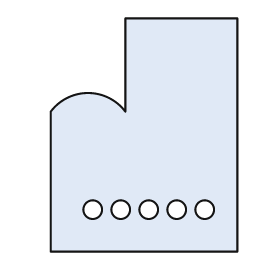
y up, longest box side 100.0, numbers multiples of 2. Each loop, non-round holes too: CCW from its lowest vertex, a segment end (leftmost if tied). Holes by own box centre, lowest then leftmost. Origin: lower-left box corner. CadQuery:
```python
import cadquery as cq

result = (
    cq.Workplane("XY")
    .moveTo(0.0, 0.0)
    .lineTo(80.0, 0.0)
    .lineTo(80.0, 100.0)
    .lineTo(32.0, 100.0)
    .lineTo(32.0, 60.0)
    .threePointArc((16.0, 68.0), (0.0, 60.0))
    .close()
    .moveTo(18.0, 18.0)
    .circle(4.0)
    .moveTo(30.0, 18.0)
    .circle(4.0)
    .moveTo(42.0, 18.0)
    .circle(4.0)
    .moveTo(54.0, 18.0)
    .circle(4.0)
    .moveTo(66.0, 18.0)
    .circle(4.0)
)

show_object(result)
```